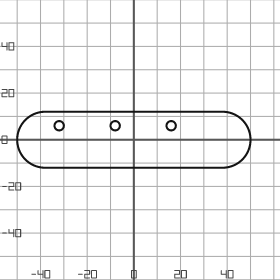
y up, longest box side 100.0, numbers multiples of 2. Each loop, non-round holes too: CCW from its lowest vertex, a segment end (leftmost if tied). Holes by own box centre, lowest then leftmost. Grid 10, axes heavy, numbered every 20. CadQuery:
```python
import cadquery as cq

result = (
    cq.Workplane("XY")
    .moveTo(-38.0, -12.0)
    .lineTo(38.0, -12.0)
    .threePointArc((50.0, 0.0), (38.0, 12.0))
    .lineTo(-38.0, 12.0)
    .threePointArc((-50.0, 0.0), (-38.0, -12.0))
    .close()
    .moveTo(-32.0, 6.0)
    .circle(2.0)
    .moveTo(-8.0, 6.0)
    .circle(2.0)
    .moveTo(16.0, 6.0)
    .circle(2.0)
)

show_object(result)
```